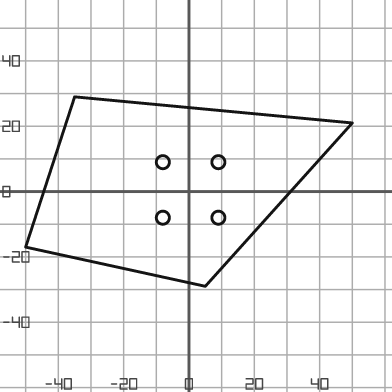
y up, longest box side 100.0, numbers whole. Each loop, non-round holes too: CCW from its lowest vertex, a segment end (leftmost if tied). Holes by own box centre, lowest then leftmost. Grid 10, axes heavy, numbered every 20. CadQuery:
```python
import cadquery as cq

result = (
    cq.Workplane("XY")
    .moveTo(5.0, -29.0)
    .lineTo(50.0, 21.0)
    .lineTo(-35.0, 29.0)
    .lineTo(-50.0, -17.0)
    .close()
    .moveTo(-8.0, -8.0)
    .circle(2.0)
    .moveTo(9.0, -8.0)
    .circle(2.0)
    .moveTo(-8.0, 9.0)
    .circle(2.0)
    .moveTo(9.0, 9.0)
    .circle(2.0)
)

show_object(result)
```